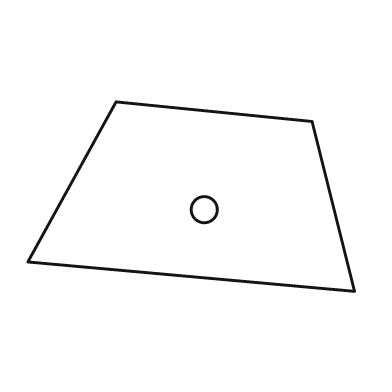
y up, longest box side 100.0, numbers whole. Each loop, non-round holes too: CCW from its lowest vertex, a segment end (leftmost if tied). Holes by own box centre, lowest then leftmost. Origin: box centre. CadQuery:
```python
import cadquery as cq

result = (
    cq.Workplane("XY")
    .moveTo(50.0, -29.0)
    .lineTo(37.0, 23.0)
    .lineTo(-23.0, 29.0)
    .lineTo(-50.0, -20.0)
    .close()
    .moveTo(4.0, -4.0)
    .circle(4.0)
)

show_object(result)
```